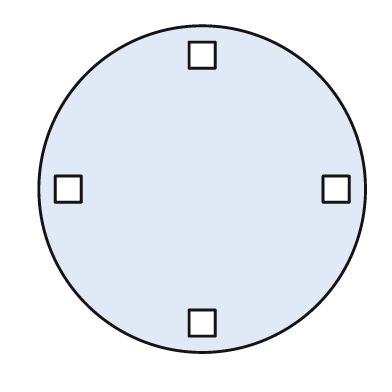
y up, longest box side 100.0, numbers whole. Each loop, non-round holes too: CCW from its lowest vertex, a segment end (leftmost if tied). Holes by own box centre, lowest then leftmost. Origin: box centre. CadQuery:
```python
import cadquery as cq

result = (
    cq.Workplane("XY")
    .moveTo(0.0, 0.0)
    .circle(50.0)
    .moveTo(-4.0, -45.0)
    .lineTo(4.0, -45.0)
    .lineTo(4.0, -37.0)
    .lineTo(-4.0, -37.0)
    .close()
    .moveTo(-45.0, -4.0)
    .lineTo(-37.0, -4.0)
    .lineTo(-37.0, 4.0)
    .lineTo(-45.0, 4.0)
    .close()
    .moveTo(37.0, -4.0)
    .lineTo(45.0, -4.0)
    .lineTo(45.0, 4.0)
    .lineTo(37.0, 4.0)
    .close()
    .moveTo(-4.0, 37.0)
    .lineTo(4.0, 37.0)
    .lineTo(4.0, 45.0)
    .lineTo(-4.0, 45.0)
    .close()
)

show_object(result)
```